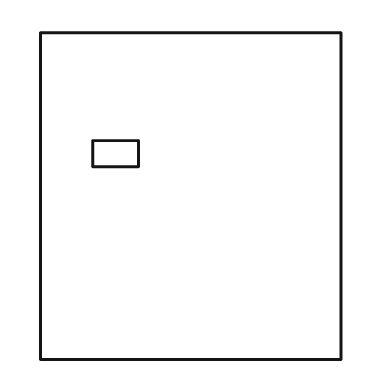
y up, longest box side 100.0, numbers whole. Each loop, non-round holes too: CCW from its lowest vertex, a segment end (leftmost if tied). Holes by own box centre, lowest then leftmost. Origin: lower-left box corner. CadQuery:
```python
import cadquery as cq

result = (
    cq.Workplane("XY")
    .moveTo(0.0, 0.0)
    .lineTo(92.0, 0.0)
    .lineTo(92.0, 100.0)
    .lineTo(0.0, 100.0)
    .close()
    .moveTo(16.0, 59.0)
    .lineTo(30.0, 59.0)
    .lineTo(30.0, 67.0)
    .lineTo(16.0, 67.0)
    .close()
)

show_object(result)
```